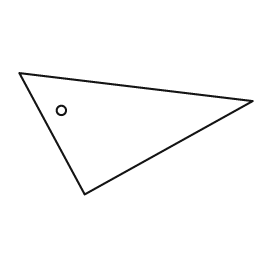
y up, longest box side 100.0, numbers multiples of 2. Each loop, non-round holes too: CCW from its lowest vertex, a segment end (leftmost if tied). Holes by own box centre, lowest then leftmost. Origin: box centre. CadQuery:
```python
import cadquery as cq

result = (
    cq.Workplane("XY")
    .moveTo(-22.0, -26.0)
    .lineTo(50.0, 14.0)
    .lineTo(-50.0, 26.0)
    .close()
    .moveTo(-32.0, 10.0)
    .circle(2.0)
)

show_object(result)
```